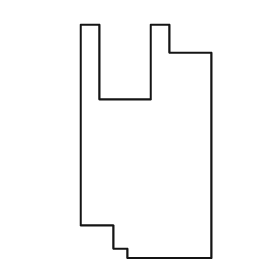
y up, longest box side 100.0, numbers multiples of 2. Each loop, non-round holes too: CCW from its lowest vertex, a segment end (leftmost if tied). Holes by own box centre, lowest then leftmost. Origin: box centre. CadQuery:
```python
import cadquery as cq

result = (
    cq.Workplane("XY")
    .moveTo(-8.0, -50.0)
    .lineTo(28.0, -50.0)
    .lineTo(28.0, 38.0)
    .lineTo(10.0, 38.0)
    .lineTo(10.0, 50.0)
    .lineTo(2.0, 50.0)
    .lineTo(2.0, 18.0)
    .lineTo(-20.0, 18.0)
    .lineTo(-20.0, 50.0)
    .lineTo(-28.0, 50.0)
    .lineTo(-28.0, -36.0)
    .lineTo(-14.0, -36.0)
    .lineTo(-14.0, -46.0)
    .lineTo(-8.0, -46.0)
    .close()
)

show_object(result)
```